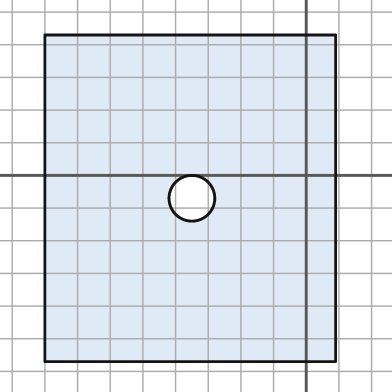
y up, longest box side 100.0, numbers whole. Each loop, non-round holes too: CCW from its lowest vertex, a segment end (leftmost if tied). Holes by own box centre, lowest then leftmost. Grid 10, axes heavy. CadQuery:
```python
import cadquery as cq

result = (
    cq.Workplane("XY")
    .moveTo(-80.0, -57.0)
    .lineTo(9.0, -57.0)
    .lineTo(9.0, 43.0)
    .lineTo(-80.0, 43.0)
    .close()
    .moveTo(-35.0, -7.0)
    .circle(7.0)
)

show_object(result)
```